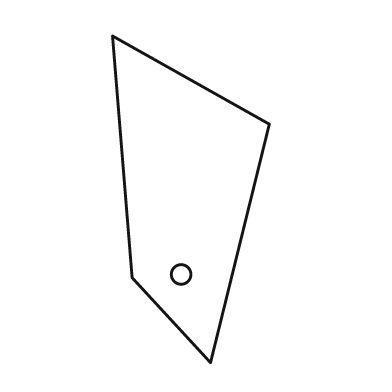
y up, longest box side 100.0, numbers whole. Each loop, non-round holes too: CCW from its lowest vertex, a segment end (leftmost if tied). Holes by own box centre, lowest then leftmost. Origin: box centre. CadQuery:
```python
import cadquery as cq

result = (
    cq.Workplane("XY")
    .moveTo(6.0, -50.0)
    .lineTo(24.0, 23.0)
    .lineTo(-24.0, 50.0)
    .lineTo(-18.0, -24.0)
    .close()
    .moveTo(-3.0, -23.0)
    .circle(3.0)
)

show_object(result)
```